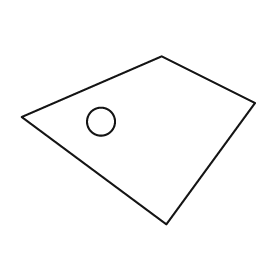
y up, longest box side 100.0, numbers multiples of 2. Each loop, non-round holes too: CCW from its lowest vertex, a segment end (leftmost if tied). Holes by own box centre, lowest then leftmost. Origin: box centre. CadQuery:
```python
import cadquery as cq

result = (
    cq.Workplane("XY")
    .moveTo(12.0, -36.0)
    .lineTo(50.0, 16.0)
    .lineTo(10.0, 36.0)
    .lineTo(-50.0, 10.0)
    .close()
    .moveTo(-16.0, 8.0)
    .circle(6.0)
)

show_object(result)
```